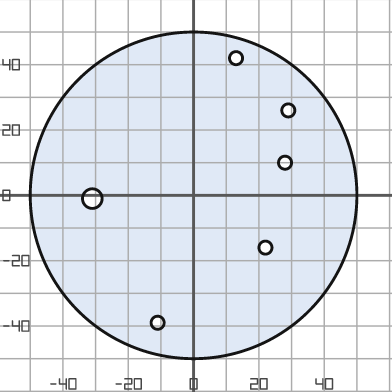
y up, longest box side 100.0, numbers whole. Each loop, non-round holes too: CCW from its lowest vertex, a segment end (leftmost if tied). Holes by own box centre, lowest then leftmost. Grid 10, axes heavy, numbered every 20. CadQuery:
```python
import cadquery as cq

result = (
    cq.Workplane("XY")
    .moveTo(0.0, 0.0)
    .circle(50.0)
    .moveTo(-11.0, -39.0)
    .circle(2.0)
    .moveTo(22.0, -16.0)
    .circle(2.0)
    .moveTo(-31.0, -1.0)
    .circle(3.0)
    .moveTo(28.0, 10.0)
    .circle(2.0)
    .moveTo(29.0, 26.0)
    .circle(2.0)
    .moveTo(13.0, 42.0)
    .circle(2.0)
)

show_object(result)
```